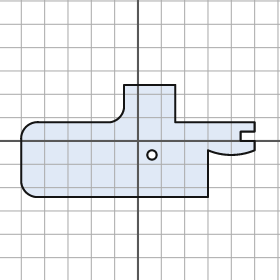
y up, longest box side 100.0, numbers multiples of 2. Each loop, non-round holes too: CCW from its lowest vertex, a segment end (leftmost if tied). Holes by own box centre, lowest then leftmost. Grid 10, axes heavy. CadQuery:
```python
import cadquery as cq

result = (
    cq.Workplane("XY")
    .moveTo(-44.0, -24.0)
    .lineTo(30.0, -24.0)
    .lineTo(30.0, -4.0)
    .threePointArc((40.0, -6.0), (50.0, -4.0))
    .lineTo(50.0, 0.0)
    .lineTo(44.0, 0.0)
    .lineTo(44.0, 4.0)
    .lineTo(50.0, 4.0)
    .lineTo(50.0, 8.0)
    .lineTo(16.0, 8.0)
    .lineTo(16.0, 24.0)
    .lineTo(-6.0, 24.0)
    .lineTo(-6.0, 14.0)
    .threePointArc((-8.0, 10.0), (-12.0, 8.0))
    .lineTo(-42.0, 8.0)
    .threePointArc((-48.0, 6.0), (-50.0, 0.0))
    .lineTo(-50.0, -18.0)
    .threePointArc((-48.0, -22.0), (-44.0, -24.0))
    .close()
    .moveTo(6.0, -6.0)
    .circle(2.0)
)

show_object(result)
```